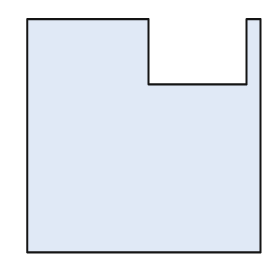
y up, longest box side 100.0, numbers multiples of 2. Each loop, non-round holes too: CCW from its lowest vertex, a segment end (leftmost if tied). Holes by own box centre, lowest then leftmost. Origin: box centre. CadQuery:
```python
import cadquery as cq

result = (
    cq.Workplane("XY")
    .moveTo(-50.0, -50.0)
    .lineTo(50.0, -50.0)
    .lineTo(50.0, 50.0)
    .lineTo(44.0, 50.0)
    .lineTo(44.0, 22.0)
    .lineTo(2.0, 22.0)
    .lineTo(2.0, 50.0)
    .lineTo(-50.0, 50.0)
    .close()
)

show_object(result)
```